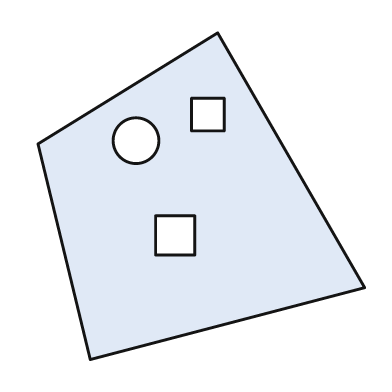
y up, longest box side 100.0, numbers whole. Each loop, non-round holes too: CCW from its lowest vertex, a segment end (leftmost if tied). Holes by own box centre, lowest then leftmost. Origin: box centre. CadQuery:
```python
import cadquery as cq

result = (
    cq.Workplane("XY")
    .moveTo(-34.0, -50.0)
    .lineTo(50.0, -28.0)
    .lineTo(5.0, 50.0)
    .lineTo(-50.0, 16.0)
    .close()
    .moveTo(-14.0, -18.0)
    .lineTo(-2.0, -18.0)
    .lineTo(-2.0, -6.0)
    .lineTo(-14.0, -6.0)
    .close()
    .moveTo(-20.0, 17.0)
    .circle(7.0)
    .moveTo(-3.0, 20.0)
    .lineTo(7.0, 20.0)
    .lineTo(7.0, 30.0)
    .lineTo(-3.0, 30.0)
    .close()
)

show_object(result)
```